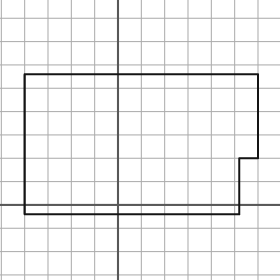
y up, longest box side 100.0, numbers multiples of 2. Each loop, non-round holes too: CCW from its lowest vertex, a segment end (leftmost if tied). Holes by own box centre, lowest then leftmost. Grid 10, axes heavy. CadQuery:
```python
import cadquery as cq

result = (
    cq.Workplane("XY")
    .moveTo(-40.0, -4.0)
    .lineTo(52.0, -4.0)
    .lineTo(52.0, 20.0)
    .lineTo(60.0, 20.0)
    .lineTo(60.0, 56.0)
    .lineTo(-40.0, 56.0)
    .close()
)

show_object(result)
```